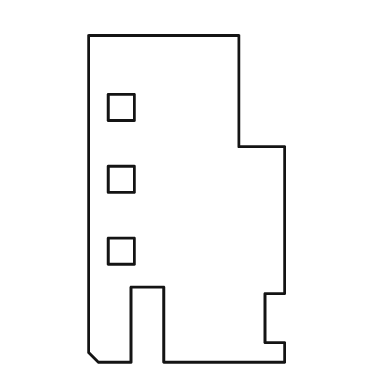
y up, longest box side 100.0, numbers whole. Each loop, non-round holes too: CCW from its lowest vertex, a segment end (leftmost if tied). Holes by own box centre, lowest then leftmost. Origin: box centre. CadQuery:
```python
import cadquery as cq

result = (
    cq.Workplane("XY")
    .moveTo(-27.0, -50.0)
    .lineTo(-17.0, -50.0)
    .lineTo(-17.0, -27.0)
    .lineTo(-7.0, -27.0)
    .lineTo(-7.0, -50.0)
    .lineTo(30.0, -50.0)
    .lineTo(30.0, -44.0)
    .lineTo(24.0, -44.0)
    .lineTo(24.0, -29.0)
    .lineTo(30.0, -29.0)
    .lineTo(30.0, 16.0)
    .lineTo(16.0, 16.0)
    .lineTo(16.0, 50.0)
    .lineTo(-30.0, 50.0)
    .lineTo(-30.0, -47.0)
    .close()
    .moveTo(-24.0, -20.0)
    .lineTo(-16.0, -20.0)
    .lineTo(-16.0, -12.0)
    .lineTo(-24.0, -12.0)
    .close()
    .moveTo(-24.0, 2.0)
    .lineTo(-16.0, 2.0)
    .lineTo(-16.0, 10.0)
    .lineTo(-24.0, 10.0)
    .close()
    .moveTo(-24.0, 24.0)
    .lineTo(-16.0, 24.0)
    .lineTo(-16.0, 32.0)
    .lineTo(-24.0, 32.0)
    .close()
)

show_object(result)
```